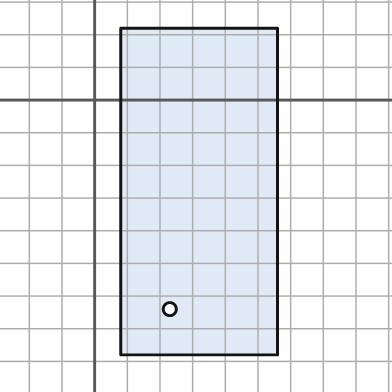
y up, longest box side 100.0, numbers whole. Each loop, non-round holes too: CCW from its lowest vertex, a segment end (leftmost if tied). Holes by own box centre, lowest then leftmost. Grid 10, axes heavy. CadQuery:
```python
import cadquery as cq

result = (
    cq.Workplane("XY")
    .moveTo(8.0, -78.0)
    .lineTo(56.0, -78.0)
    .lineTo(56.0, 22.0)
    .lineTo(8.0, 22.0)
    .close()
    .moveTo(23.0, -64.0)
    .circle(2.0)
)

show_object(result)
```